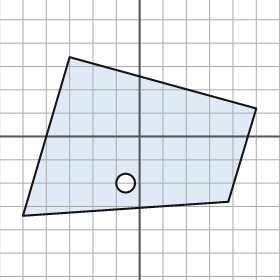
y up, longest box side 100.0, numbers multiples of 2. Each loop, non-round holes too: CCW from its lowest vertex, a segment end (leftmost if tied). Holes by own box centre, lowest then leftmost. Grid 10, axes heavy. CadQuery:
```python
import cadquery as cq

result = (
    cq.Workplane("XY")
    .moveTo(-50.0, -34.0)
    .lineTo(38.0, -28.0)
    .lineTo(50.0, 12.0)
    .lineTo(-30.0, 34.0)
    .close()
    .moveTo(-6.0, -20.0)
    .circle(4.0)
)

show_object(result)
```